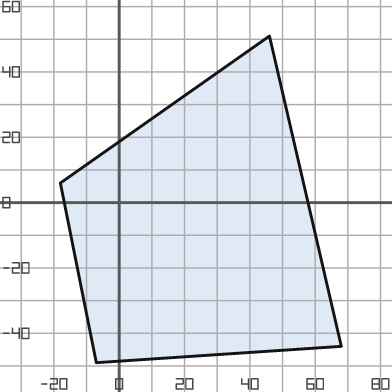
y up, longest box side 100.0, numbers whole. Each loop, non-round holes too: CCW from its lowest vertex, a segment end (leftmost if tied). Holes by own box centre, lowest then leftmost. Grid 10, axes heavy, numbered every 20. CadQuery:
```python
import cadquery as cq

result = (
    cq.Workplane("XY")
    .moveTo(-7.0, -49.0)
    .lineTo(68.0, -44.0)
    .lineTo(46.0, 51.0)
    .lineTo(-18.0, 6.0)
    .close()
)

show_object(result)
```